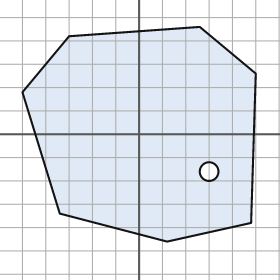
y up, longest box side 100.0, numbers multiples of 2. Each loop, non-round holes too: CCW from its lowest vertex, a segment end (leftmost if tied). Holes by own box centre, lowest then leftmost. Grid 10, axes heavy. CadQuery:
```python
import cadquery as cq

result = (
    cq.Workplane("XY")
    .moveTo(12.0, -46.0)
    .lineTo(48.0, -38.0)
    .lineTo(50.0, 26.0)
    .lineTo(26.0, 46.0)
    .lineTo(-30.0, 42.0)
    .lineTo(-50.0, 18.0)
    .lineTo(-34.0, -34.0)
    .close()
    .moveTo(30.0, -16.0)
    .circle(4.0)
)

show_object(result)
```